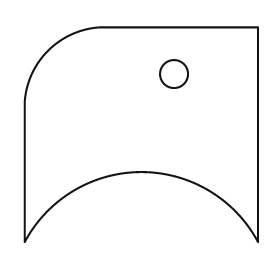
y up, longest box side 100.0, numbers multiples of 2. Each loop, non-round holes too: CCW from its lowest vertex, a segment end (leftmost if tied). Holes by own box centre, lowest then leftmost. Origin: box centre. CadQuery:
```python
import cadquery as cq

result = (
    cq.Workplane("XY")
    .moveTo(-50.0, -46.0)
    .threePointArc((0.0, -16.0), (50.0, -46.0))
    .lineTo(50.0, 46.0)
    .lineTo(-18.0, 46.0)
    .threePointArc((-40.0, 36.0), (-50.0, 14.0))
    .close()
    .moveTo(14.0, 26.0)
    .circle(6.0)
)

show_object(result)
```